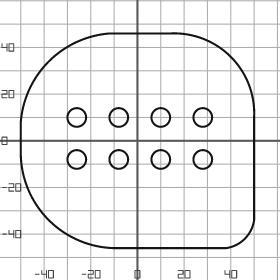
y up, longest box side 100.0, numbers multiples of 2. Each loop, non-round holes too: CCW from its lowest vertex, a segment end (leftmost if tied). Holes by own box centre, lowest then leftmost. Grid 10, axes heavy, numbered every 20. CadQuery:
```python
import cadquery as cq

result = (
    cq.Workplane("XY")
    .moveTo(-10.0, -46.0)
    .lineTo(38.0, -46.0)
    .threePointArc((46.0, -42.0), (50.0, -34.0))
    .lineTo(50.0, 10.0)
    .threePointArc((40.0, 36.0), (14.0, 46.0))
    .lineTo(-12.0, 46.0)
    .threePointArc((-38.0, 34.0), (-50.0, 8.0))
    .lineTo(-50.0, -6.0)
    .threePointArc((-38.0, -34.0), (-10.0, -46.0))
    .close()
    .moveTo(-26.0, -8.0)
    .circle(4.0)
    .moveTo(-8.0, -8.0)
    .circle(4.0)
    .moveTo(10.0, -8.0)
    .circle(4.0)
    .moveTo(28.0, -8.0)
    .circle(4.0)
    .moveTo(-26.0, 10.0)
    .circle(4.0)
    .moveTo(-8.0, 10.0)
    .circle(4.0)
    .moveTo(10.0, 10.0)
    .circle(4.0)
    .moveTo(28.0, 10.0)
    .circle(4.0)
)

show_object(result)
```